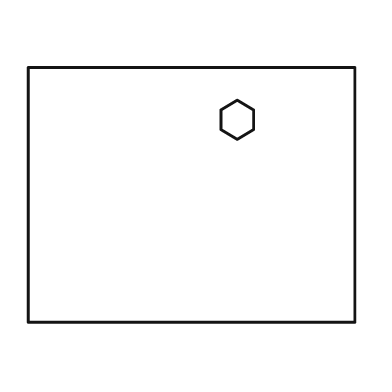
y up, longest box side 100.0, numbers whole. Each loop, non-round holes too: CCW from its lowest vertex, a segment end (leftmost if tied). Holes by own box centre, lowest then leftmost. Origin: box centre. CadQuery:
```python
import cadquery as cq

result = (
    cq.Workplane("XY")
    .moveTo(-50.0, -39.0)
    .lineTo(50.0, -39.0)
    .lineTo(50.0, 39.0)
    .lineTo(-50.0, 39.0)
    .close()
    .moveTo(14.0, 17.0)
    .lineTo(19.0, 20.0)
    .lineTo(19.0, 26.0)
    .lineTo(14.0, 29.0)
    .lineTo(9.0, 26.0)
    .lineTo(9.0, 20.0)
    .close()
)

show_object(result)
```